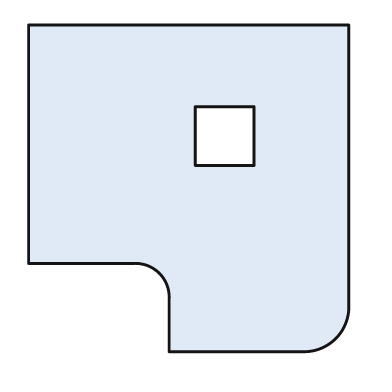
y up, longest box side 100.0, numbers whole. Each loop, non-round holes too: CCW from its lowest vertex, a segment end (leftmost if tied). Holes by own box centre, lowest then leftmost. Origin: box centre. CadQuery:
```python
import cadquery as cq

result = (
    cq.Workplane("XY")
    .moveTo(-6.0, -50.0)
    .lineTo(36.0, -50.0)
    .threePointArc((45.0, -46.0), (49.0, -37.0))
    .lineTo(49.0, 50.0)
    .lineTo(-49.0, 50.0)
    .lineTo(-49.0, -23.0)
    .lineTo(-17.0, -23.0)
    .threePointArc((-9.0, -26.0), (-6.0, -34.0))
    .close()
    .moveTo(2.0, 7.0)
    .lineTo(20.0, 7.0)
    .lineTo(20.0, 25.0)
    .lineTo(2.0, 25.0)
    .close()
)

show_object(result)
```